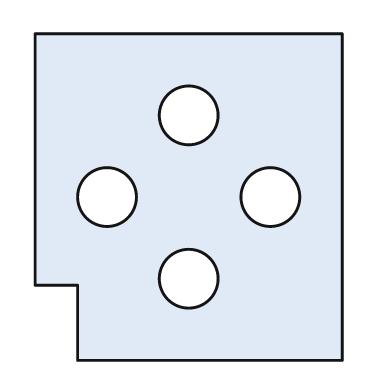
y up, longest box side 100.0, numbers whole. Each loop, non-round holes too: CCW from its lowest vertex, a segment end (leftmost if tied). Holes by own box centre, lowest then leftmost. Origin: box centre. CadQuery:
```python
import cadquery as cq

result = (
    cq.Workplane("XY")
    .moveTo(-34.0, -50.0)
    .lineTo(47.0, -50.0)
    .lineTo(47.0, 50.0)
    .lineTo(-47.0, 50.0)
    .lineTo(-47.0, -27.0)
    .lineTo(-34.0, -27.0)
    .close()
    .moveTo(0.0, -25.0)
    .circle(9.0)
    .moveTo(-25.0, 0.0)
    .circle(9.0)
    .moveTo(25.0, 0.0)
    .circle(9.0)
    .moveTo(0.0, 25.0)
    .circle(9.0)
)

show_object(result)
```